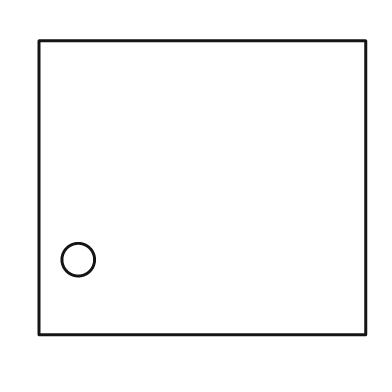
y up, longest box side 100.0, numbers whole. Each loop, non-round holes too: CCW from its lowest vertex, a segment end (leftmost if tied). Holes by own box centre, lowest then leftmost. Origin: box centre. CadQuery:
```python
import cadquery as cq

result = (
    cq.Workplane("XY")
    .moveTo(-50.0, -45.0)
    .lineTo(50.0, -45.0)
    .lineTo(50.0, 45.0)
    .lineTo(-50.0, 45.0)
    .close()
    .moveTo(-38.0, -22.0)
    .circle(5.0)
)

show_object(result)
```